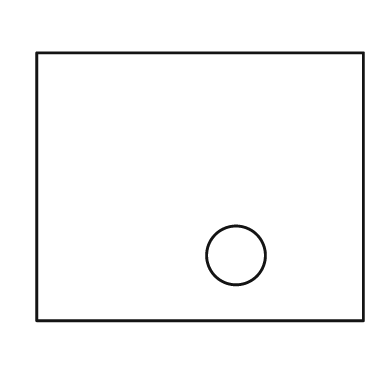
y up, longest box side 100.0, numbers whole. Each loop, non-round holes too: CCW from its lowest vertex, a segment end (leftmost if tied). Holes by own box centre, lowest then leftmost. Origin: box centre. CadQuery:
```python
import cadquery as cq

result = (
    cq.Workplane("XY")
    .moveTo(-50.0, -41.0)
    .lineTo(50.0, -41.0)
    .lineTo(50.0, 41.0)
    .lineTo(-50.0, 41.0)
    .close()
    .moveTo(11.0, -21.0)
    .circle(9.0)
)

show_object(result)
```